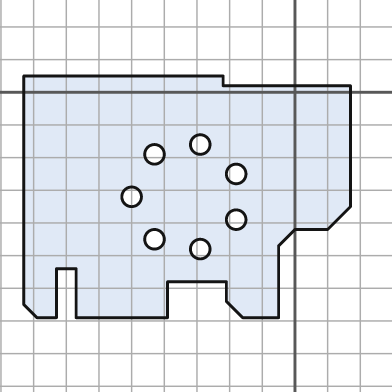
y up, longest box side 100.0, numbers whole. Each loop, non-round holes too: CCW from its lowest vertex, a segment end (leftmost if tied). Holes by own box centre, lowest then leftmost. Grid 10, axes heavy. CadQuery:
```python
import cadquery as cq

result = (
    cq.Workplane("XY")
    .moveTo(-79.0, -69.0)
    .lineTo(-73.0, -69.0)
    .lineTo(-73.0, -54.0)
    .lineTo(-67.0, -54.0)
    .lineTo(-67.0, -69.0)
    .lineTo(-39.0, -69.0)
    .lineTo(-39.0, -58.0)
    .lineTo(-21.0, -58.0)
    .lineTo(-21.0, -64.0)
    .lineTo(-16.0, -69.0)
    .lineTo(-5.0, -69.0)
    .lineTo(-5.0, -47.0)
    .lineTo(0.0, -42.0)
    .lineTo(10.0, -42.0)
    .lineTo(17.0, -35.0)
    .lineTo(17.0, 2.0)
    .lineTo(-22.0, 2.0)
    .lineTo(-22.0, 5.0)
    .lineTo(-83.0, 5.0)
    .lineTo(-83.0, -65.0)
    .close()
    .moveTo(-29.0, -48.0)
    .circle(3.0)
    .moveTo(-43.0, -45.0)
    .circle(3.0)
    .moveTo(-18.0, -39.0)
    .circle(3.0)
    .moveTo(-50.0, -32.0)
    .circle(3.0)
    .moveTo(-18.0, -25.0)
    .circle(3.0)
    .moveTo(-43.0, -19.0)
    .circle(3.0)
    .moveTo(-29.0, -16.0)
    .circle(3.0)
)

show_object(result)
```